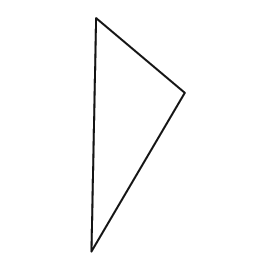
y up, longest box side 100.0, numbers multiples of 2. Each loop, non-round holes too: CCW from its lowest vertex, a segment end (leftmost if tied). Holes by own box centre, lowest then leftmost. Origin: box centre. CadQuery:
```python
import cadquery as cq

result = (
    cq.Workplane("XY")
    .moveTo(-20.0, -50.0)
    .lineTo(20.0, 18.0)
    .lineTo(-18.0, 50.0)
    .close()
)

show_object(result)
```